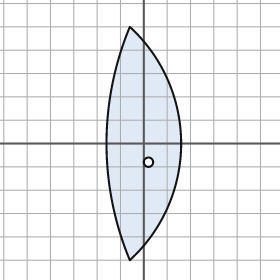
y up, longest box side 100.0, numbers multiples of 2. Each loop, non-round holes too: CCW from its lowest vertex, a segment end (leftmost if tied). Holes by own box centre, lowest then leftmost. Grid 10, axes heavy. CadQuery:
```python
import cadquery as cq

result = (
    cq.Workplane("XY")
    .moveTo(-6.0, -50.0)
    .threePointArc((16.0, 0.0), (-6.0, 50.0))
    .threePointArc((-16.0, 0.0), (-6.0, -50.0))
    .close()
    .moveTo(2.0, -8.0)
    .circle(2.0)
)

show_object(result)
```